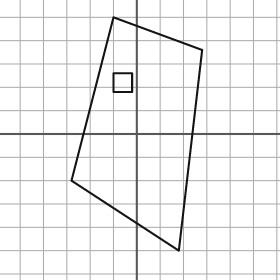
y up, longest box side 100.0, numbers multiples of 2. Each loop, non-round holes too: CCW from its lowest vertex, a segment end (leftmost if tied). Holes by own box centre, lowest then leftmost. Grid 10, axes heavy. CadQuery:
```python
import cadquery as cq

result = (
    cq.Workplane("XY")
    .moveTo(18.0, -50.0)
    .lineTo(28.0, 36.0)
    .lineTo(-10.0, 50.0)
    .lineTo(-28.0, -20.0)
    .close()
    .moveTo(-10.0, 18.0)
    .lineTo(-2.0, 18.0)
    .lineTo(-2.0, 26.0)
    .lineTo(-10.0, 26.0)
    .close()
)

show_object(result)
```